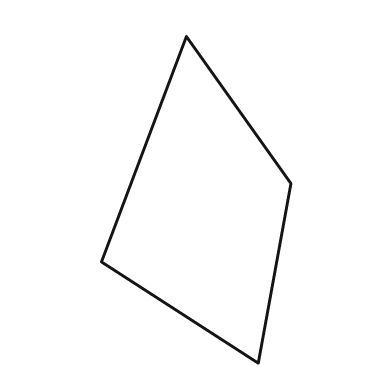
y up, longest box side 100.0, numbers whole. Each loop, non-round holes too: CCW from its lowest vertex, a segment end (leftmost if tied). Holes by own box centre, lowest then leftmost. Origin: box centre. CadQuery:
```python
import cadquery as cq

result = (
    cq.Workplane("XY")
    .moveTo(19.0, -50.0)
    .lineTo(29.0, 5.0)
    .lineTo(-3.0, 50.0)
    .lineTo(-29.0, -19.0)
    .close()
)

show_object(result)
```